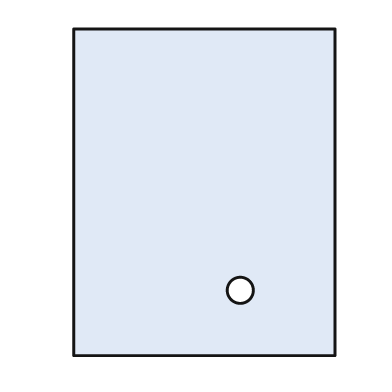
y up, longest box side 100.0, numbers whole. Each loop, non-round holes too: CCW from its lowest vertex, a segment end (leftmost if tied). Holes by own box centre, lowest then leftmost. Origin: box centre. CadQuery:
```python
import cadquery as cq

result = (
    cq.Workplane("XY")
    .moveTo(-40.0, -50.0)
    .lineTo(40.0, -50.0)
    .lineTo(40.0, 50.0)
    .lineTo(-40.0, 50.0)
    .close()
    .moveTo(11.0, -30.0)
    .circle(4.0)
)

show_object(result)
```